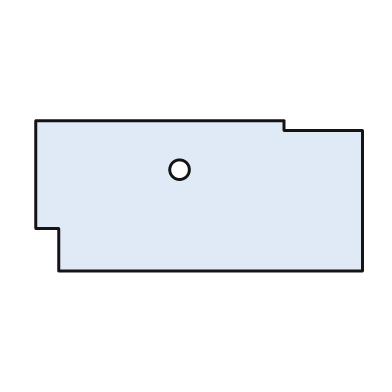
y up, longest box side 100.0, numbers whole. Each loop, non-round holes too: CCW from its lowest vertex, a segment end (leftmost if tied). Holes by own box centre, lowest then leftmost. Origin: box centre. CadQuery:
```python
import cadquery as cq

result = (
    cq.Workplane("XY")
    .moveTo(-43.0, -23.0)
    .lineTo(50.0, -23.0)
    .lineTo(50.0, 20.0)
    .lineTo(26.0, 20.0)
    .lineTo(26.0, 23.0)
    .lineTo(-50.0, 23.0)
    .lineTo(-50.0, -10.0)
    .lineTo(-43.0, -10.0)
    .close()
    .moveTo(-6.0, 8.0)
    .circle(3.0)
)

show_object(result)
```